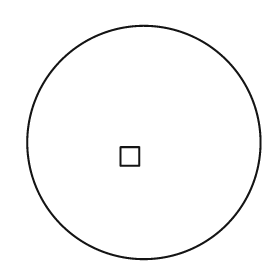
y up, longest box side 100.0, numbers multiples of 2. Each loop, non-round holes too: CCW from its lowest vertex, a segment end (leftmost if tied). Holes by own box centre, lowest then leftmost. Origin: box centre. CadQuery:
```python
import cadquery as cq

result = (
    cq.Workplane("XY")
    .moveTo(0.0, 0.0)
    .circle(50.0)
    .moveTo(-10.0, -10.0)
    .lineTo(-2.0, -10.0)
    .lineTo(-2.0, -2.0)
    .lineTo(-10.0, -2.0)
    .close()
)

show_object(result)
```